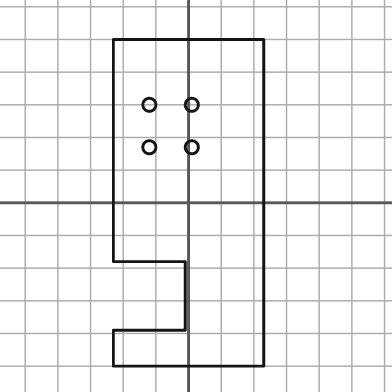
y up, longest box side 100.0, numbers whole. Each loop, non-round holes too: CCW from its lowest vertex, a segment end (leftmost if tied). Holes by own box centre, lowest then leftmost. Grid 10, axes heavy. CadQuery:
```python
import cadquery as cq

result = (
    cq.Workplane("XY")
    .moveTo(-23.0, -50.0)
    .lineTo(23.0, -50.0)
    .lineTo(23.0, 50.0)
    .lineTo(-23.0, 50.0)
    .lineTo(-23.0, -18.0)
    .lineTo(-1.0, -18.0)
    .lineTo(-1.0, -39.0)
    .lineTo(-23.0, -39.0)
    .close()
    .moveTo(-12.0, 17.0)
    .circle(2.0)
    .moveTo(1.0, 17.0)
    .circle(2.0)
    .moveTo(-12.0, 30.0)
    .circle(2.0)
    .moveTo(1.0, 30.0)
    .circle(2.0)
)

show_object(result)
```